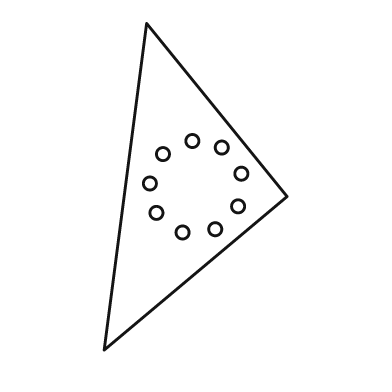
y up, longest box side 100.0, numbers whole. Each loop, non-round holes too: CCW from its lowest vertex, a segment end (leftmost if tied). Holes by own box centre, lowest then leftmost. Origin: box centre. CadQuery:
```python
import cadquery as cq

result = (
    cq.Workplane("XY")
    .moveTo(-28.0, -50.0)
    .lineTo(28.0, -3.0)
    .lineTo(-15.0, 50.0)
    .close()
    .moveTo(-4.0, -14.0)
    .circle(2.0)
    .moveTo(6.0, -13.0)
    .circle(2.0)
    .moveTo(-12.0, -8.0)
    .circle(2.0)
    .moveTo(13.0, -6.0)
    .circle(2.0)
    .moveTo(-14.0, 1.0)
    .circle(2.0)
    .moveTo(14.0, 4.0)
    .circle(2.0)
    .moveTo(-10.0, 10.0)
    .circle(2.0)
    .moveTo(8.0, 12.0)
    .circle(2.0)
    .moveTo(-1.0, 14.0)
    .circle(2.0)
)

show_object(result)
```